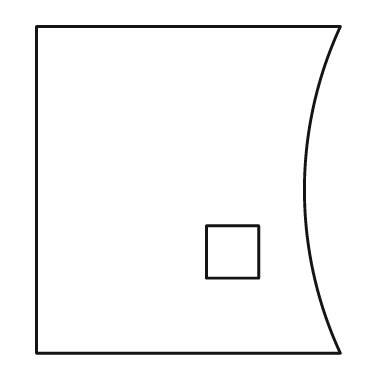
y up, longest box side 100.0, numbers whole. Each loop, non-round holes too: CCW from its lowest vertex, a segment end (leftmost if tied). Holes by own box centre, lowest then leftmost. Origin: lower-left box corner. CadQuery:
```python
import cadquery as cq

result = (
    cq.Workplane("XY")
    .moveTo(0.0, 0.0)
    .lineTo(93.0, 0.0)
    .threePointArc((82.0, 50.0), (93.0, 100.0))
    .lineTo(0.0, 100.0)
    .close()
    .moveTo(52.0, 23.0)
    .lineTo(68.0, 23.0)
    .lineTo(68.0, 39.0)
    .lineTo(52.0, 39.0)
    .close()
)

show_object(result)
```